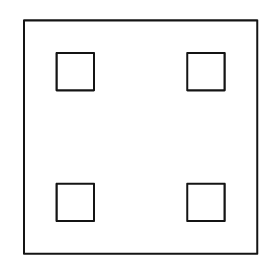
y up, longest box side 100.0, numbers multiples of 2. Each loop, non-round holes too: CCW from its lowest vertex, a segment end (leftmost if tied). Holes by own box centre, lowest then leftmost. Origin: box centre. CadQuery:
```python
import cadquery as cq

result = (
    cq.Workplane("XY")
    .moveTo(-50.0, -50.0)
    .lineTo(50.0, -50.0)
    .lineTo(50.0, 50.0)
    .lineTo(-50.0, 50.0)
    .close()
    .moveTo(-36.0, -36.0)
    .lineTo(-20.0, -36.0)
    .lineTo(-20.0, -20.0)
    .lineTo(-36.0, -20.0)
    .close()
    .moveTo(20.0, -36.0)
    .lineTo(36.0, -36.0)
    .lineTo(36.0, -20.0)
    .lineTo(20.0, -20.0)
    .close()
    .moveTo(-36.0, 20.0)
    .lineTo(-20.0, 20.0)
    .lineTo(-20.0, 36.0)
    .lineTo(-36.0, 36.0)
    .close()
    .moveTo(20.0, 20.0)
    .lineTo(36.0, 20.0)
    .lineTo(36.0, 36.0)
    .lineTo(20.0, 36.0)
    .close()
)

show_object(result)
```